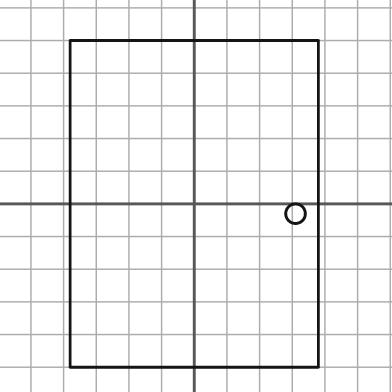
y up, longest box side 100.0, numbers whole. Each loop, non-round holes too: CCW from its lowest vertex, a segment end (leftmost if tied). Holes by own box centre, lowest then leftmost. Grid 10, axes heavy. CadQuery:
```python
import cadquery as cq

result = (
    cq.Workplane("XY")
    .moveTo(-38.0, -50.0)
    .lineTo(38.0, -50.0)
    .lineTo(38.0, 50.0)
    .lineTo(-38.0, 50.0)
    .close()
    .moveTo(31.0, -3.0)
    .circle(3.0)
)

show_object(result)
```